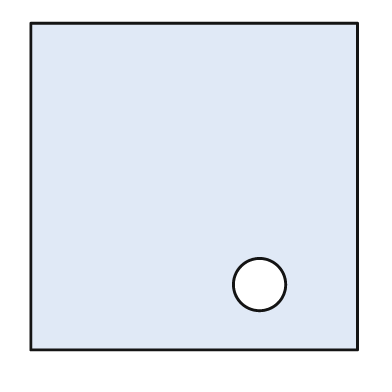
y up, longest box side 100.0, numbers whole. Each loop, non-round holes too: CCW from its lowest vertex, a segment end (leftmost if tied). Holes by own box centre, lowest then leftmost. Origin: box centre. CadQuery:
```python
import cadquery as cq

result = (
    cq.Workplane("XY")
    .moveTo(-50.0, -50.0)
    .lineTo(50.0, -50.0)
    .lineTo(50.0, 50.0)
    .lineTo(-50.0, 50.0)
    .close()
    .moveTo(20.0, -30.0)
    .circle(8.0)
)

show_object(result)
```